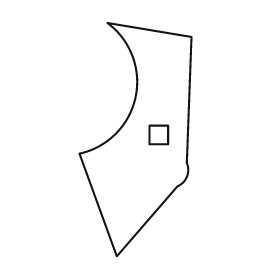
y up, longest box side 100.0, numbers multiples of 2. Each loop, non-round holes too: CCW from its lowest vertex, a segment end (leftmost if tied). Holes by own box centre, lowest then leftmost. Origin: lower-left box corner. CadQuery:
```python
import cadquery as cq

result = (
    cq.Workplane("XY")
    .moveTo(16.0, 0.0)
    .lineTo(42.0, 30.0)
    .threePointArc((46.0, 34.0), (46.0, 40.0))
    .lineTo(48.0, 94.0)
    .lineTo(12.0, 100.0)
    .threePointArc((24.0, 68.0), (0.0, 44.0))
    .close()
    .moveTo(30.0, 48.0)
    .lineTo(38.0, 48.0)
    .lineTo(38.0, 56.0)
    .lineTo(30.0, 56.0)
    .close()
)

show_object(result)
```